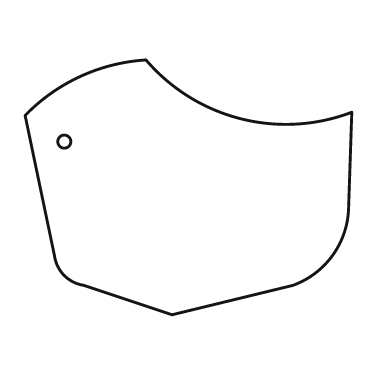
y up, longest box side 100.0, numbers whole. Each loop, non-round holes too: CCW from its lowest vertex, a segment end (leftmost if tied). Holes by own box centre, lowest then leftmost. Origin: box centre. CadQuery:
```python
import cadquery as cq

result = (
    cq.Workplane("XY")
    .moveTo(-5.0, -39.0)
    .lineTo(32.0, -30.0)
    .threePointArc((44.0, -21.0), (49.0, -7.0))
    .lineTo(50.0, 23.0)
    .threePointArc((16.0, 21.0), (-13.0, 39.0))
    .threePointArc((-33.0, 34.0), (-50.0, 22.0))
    .lineTo(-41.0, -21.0)
    .threePointArc((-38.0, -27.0), (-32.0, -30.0))
    .close()
    .moveTo(-38.0, 14.0)
    .circle(2.0)
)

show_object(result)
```